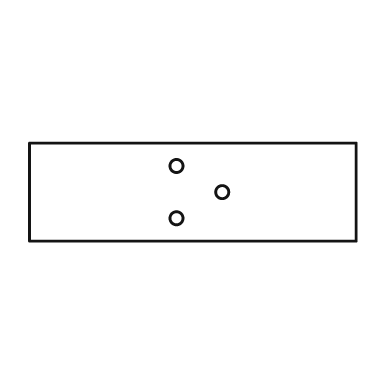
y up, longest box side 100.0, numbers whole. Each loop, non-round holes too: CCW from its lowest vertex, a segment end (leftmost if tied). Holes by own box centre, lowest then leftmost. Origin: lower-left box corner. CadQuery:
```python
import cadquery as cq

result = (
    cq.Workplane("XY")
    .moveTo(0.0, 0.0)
    .lineTo(100.0, 0.0)
    .lineTo(100.0, 30.0)
    .lineTo(0.0, 30.0)
    .close()
    .moveTo(45.0, 7.0)
    .circle(2.0)
    .moveTo(59.0, 15.0)
    .circle(2.0)
    .moveTo(45.0, 23.0)
    .circle(2.0)
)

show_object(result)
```